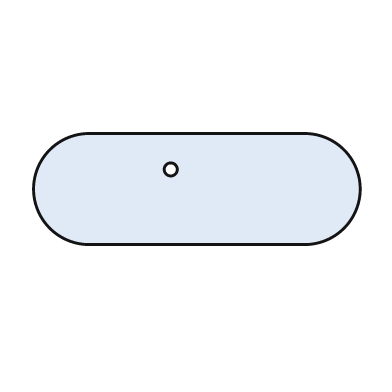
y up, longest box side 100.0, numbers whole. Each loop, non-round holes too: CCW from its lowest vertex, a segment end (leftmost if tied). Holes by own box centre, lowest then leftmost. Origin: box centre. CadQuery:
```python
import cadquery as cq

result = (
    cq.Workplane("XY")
    .moveTo(-33.0, -17.0)
    .lineTo(33.0, -17.0)
    .threePointArc((50.0, 0.0), (33.0, 17.0))
    .lineTo(-33.0, 17.0)
    .threePointArc((-50.0, 0.0), (-33.0, -17.0))
    .close()
    .moveTo(-8.0, 6.0)
    .circle(2.0)
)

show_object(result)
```